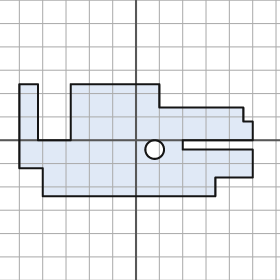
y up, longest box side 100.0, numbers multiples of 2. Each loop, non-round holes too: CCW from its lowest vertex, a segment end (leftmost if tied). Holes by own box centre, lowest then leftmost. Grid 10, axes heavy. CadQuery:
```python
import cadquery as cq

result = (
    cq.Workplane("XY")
    .moveTo(-40.0, -24.0)
    .lineTo(34.0, -24.0)
    .lineTo(34.0, -16.0)
    .lineTo(50.0, -16.0)
    .lineTo(50.0, -4.0)
    .lineTo(20.0, -4.0)
    .lineTo(20.0, 0.0)
    .lineTo(50.0, 0.0)
    .lineTo(50.0, 8.0)
    .lineTo(46.0, 8.0)
    .lineTo(46.0, 14.0)
    .lineTo(10.0, 14.0)
    .lineTo(10.0, 24.0)
    .lineTo(-28.0, 24.0)
    .lineTo(-28.0, 0.0)
    .lineTo(-42.0, 0.0)
    .lineTo(-42.0, 24.0)
    .lineTo(-50.0, 24.0)
    .lineTo(-50.0, -12.0)
    .lineTo(-40.0, -12.0)
    .close()
    .moveTo(8.0, -4.0)
    .circle(4.0)
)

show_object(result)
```